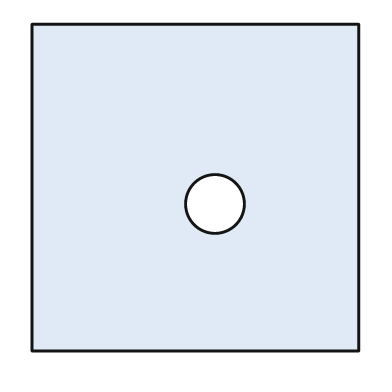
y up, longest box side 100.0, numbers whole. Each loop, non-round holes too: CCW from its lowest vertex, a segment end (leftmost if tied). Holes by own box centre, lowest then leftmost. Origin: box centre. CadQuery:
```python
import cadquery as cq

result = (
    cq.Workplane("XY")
    .moveTo(-50.0, -50.0)
    .lineTo(50.0, -50.0)
    .lineTo(50.0, 50.0)
    .lineTo(-50.0, 50.0)
    .close()
    .moveTo(6.0, -5.0)
    .circle(9.0)
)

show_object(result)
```